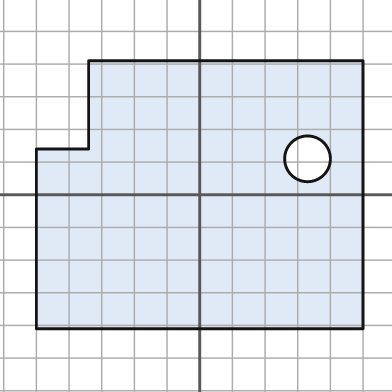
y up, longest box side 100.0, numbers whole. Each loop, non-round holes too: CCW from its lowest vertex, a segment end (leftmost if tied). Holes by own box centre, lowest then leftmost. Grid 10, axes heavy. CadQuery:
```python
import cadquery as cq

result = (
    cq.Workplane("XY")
    .moveTo(-50.0, -41.0)
    .lineTo(50.0, -41.0)
    .lineTo(50.0, 41.0)
    .lineTo(-34.0, 41.0)
    .lineTo(-34.0, 14.0)
    .lineTo(-50.0, 14.0)
    .close()
    .moveTo(33.0, 11.0)
    .circle(7.0)
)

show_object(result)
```